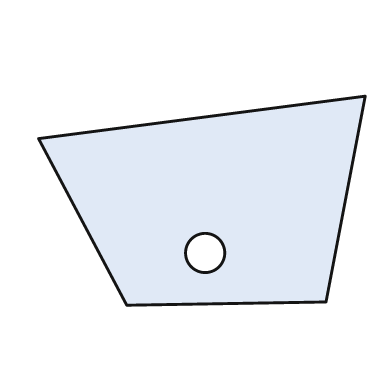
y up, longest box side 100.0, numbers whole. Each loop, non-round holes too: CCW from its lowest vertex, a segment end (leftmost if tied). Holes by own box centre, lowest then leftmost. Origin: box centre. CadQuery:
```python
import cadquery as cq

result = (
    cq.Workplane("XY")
    .moveTo(-23.0, -32.0)
    .lineTo(38.0, -31.0)
    .lineTo(50.0, 32.0)
    .lineTo(-50.0, 19.0)
    .close()
    .moveTo(1.0, -16.0)
    .circle(6.0)
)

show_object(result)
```